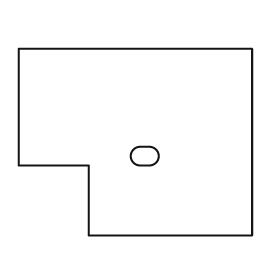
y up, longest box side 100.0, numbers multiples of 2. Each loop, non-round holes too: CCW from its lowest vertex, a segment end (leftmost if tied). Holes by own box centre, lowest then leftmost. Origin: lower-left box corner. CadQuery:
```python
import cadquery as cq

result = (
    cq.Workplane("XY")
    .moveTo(30.0, 0.0)
    .lineTo(100.0, 0.0)
    .lineTo(100.0, 80.0)
    .lineTo(0.0, 80.0)
    .lineTo(0.0, 30.0)
    .lineTo(30.0, 30.0)
    .close()
    .moveTo(52.0, 30.0)
    .lineTo(56.0, 30.0)
    .threePointArc((60.0, 34.0), (56.0, 38.0))
    .lineTo(52.0, 38.0)
    .threePointArc((48.0, 34.0), (52.0, 30.0))
    .close()
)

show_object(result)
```